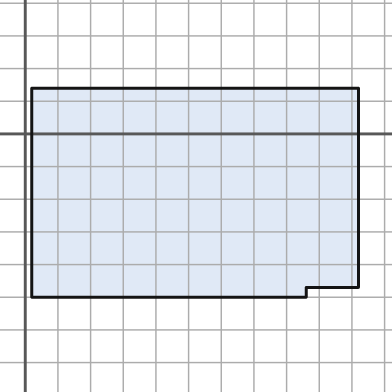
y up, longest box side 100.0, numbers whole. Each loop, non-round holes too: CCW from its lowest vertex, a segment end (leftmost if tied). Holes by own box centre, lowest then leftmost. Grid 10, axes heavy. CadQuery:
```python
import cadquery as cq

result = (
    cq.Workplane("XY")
    .moveTo(2.0, -50.0)
    .lineTo(86.0, -50.0)
    .lineTo(86.0, -47.0)
    .lineTo(102.0, -47.0)
    .lineTo(102.0, 14.0)
    .lineTo(2.0, 14.0)
    .close()
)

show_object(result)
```